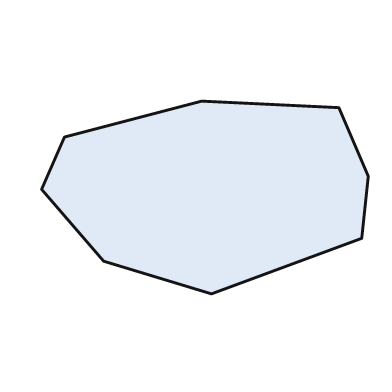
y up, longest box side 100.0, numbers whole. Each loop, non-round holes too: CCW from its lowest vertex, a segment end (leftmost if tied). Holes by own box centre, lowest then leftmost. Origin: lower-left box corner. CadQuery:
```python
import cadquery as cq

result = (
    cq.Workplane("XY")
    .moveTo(52.0, 0.0)
    .lineTo(98.0, 17.0)
    .lineTo(100.0, 36.0)
    .lineTo(91.0, 57.0)
    .lineTo(49.0, 59.0)
    .lineTo(7.0, 48.0)
    .lineTo(0.0, 32.0)
    .lineTo(19.0, 10.0)
    .close()
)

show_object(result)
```